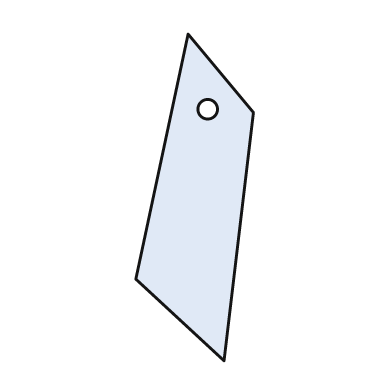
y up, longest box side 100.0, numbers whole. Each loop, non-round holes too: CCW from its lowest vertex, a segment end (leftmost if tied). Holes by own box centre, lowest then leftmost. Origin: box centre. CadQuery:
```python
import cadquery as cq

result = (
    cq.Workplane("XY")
    .moveTo(9.0, -50.0)
    .lineTo(18.0, 26.0)
    .lineTo(-2.0, 50.0)
    .lineTo(-18.0, -25.0)
    .close()
    .moveTo(4.0, 27.0)
    .circle(3.0)
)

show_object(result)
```